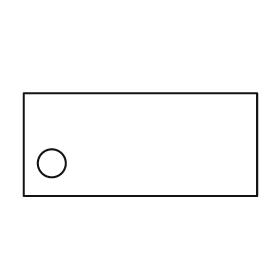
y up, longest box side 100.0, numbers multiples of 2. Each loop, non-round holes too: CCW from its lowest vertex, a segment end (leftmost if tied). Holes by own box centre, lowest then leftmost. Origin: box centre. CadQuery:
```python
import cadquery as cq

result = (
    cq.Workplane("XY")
    .moveTo(-50.0, -22.0)
    .lineTo(50.0, -22.0)
    .lineTo(50.0, 22.0)
    .lineTo(-50.0, 22.0)
    .close()
    .moveTo(-38.0, -8.0)
    .circle(6.0)
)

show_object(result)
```